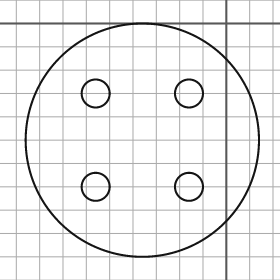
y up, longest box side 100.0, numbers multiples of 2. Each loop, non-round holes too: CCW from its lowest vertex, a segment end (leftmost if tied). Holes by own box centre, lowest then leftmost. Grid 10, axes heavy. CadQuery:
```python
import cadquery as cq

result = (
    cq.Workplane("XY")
    .moveTo(-36.0, -50.0)
    .circle(50.0)
    .moveTo(-56.0, -70.0)
    .circle(6.0)
    .moveTo(-16.0, -70.0)
    .circle(6.0)
    .moveTo(-56.0, -30.0)
    .circle(6.0)
    .moveTo(-16.0, -30.0)
    .circle(6.0)
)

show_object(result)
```